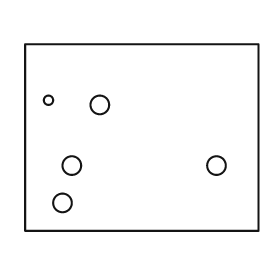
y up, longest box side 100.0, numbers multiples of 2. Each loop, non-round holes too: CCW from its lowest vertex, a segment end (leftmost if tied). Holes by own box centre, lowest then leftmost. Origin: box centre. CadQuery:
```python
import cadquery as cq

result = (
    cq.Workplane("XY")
    .moveTo(-50.0, -40.0)
    .lineTo(50.0, -40.0)
    .lineTo(50.0, 40.0)
    .lineTo(-50.0, 40.0)
    .close()
    .moveTo(-34.0, -28.0)
    .circle(4.0)
    .moveTo(-30.0, -12.0)
    .circle(4.0)
    .moveTo(32.0, -12.0)
    .circle(4.0)
    .moveTo(-18.0, 14.0)
    .circle(4.0)
    .moveTo(-40.0, 16.0)
    .circle(2.0)
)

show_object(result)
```